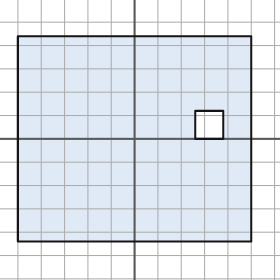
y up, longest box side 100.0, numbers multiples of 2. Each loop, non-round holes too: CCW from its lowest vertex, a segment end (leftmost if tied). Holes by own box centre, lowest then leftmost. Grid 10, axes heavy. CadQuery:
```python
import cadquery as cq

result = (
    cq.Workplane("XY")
    .moveTo(-50.0, -44.0)
    .lineTo(50.0, -44.0)
    .lineTo(50.0, 44.0)
    .lineTo(-50.0, 44.0)
    .close()
    .moveTo(26.0, 0.0)
    .lineTo(38.0, 0.0)
    .lineTo(38.0, 12.0)
    .lineTo(26.0, 12.0)
    .close()
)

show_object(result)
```